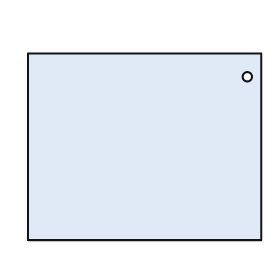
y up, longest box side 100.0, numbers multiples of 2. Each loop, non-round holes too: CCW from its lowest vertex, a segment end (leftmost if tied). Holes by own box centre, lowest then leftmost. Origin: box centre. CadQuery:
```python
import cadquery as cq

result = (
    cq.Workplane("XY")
    .moveTo(-50.0, -40.0)
    .lineTo(50.0, -40.0)
    .lineTo(50.0, 40.0)
    .lineTo(-50.0, 40.0)
    .close()
    .moveTo(44.0, 30.0)
    .circle(2.0)
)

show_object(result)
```